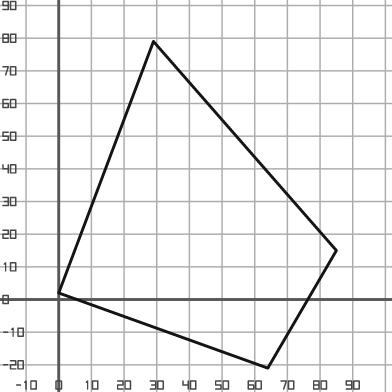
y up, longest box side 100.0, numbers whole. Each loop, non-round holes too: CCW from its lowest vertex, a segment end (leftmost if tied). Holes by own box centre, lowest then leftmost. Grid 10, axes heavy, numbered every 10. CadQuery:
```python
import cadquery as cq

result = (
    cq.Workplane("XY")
    .moveTo(64.0, -21.0)
    .lineTo(85.0, 15.0)
    .lineTo(29.0, 79.0)
    .lineTo(0.0, 2.0)
    .close()
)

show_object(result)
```